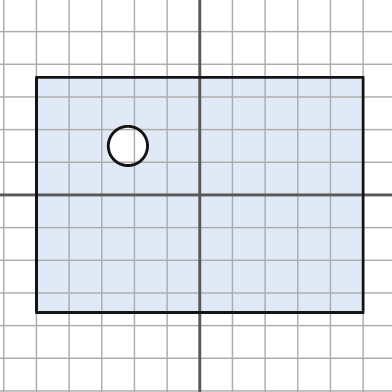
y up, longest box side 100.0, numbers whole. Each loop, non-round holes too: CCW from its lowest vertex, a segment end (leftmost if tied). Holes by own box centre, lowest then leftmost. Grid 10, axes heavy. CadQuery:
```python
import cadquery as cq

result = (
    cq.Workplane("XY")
    .moveTo(-50.0, -36.0)
    .lineTo(50.0, -36.0)
    .lineTo(50.0, 36.0)
    .lineTo(-50.0, 36.0)
    .close()
    .moveTo(-22.0, 15.0)
    .circle(6.0)
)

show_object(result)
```